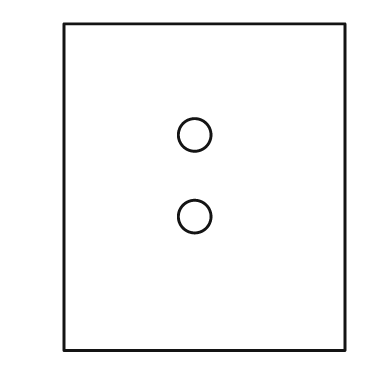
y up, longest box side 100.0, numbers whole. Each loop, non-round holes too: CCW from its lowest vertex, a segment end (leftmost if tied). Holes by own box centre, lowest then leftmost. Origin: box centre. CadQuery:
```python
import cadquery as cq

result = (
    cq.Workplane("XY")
    .moveTo(-43.0, -50.0)
    .lineTo(43.0, -50.0)
    .lineTo(43.0, 50.0)
    .lineTo(-43.0, 50.0)
    .close()
    .moveTo(-3.0, -9.0)
    .circle(5.0)
    .moveTo(-3.0, 16.0)
    .circle(5.0)
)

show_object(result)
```